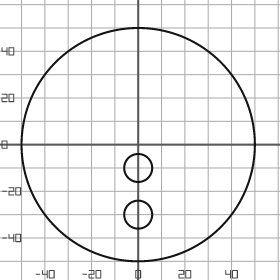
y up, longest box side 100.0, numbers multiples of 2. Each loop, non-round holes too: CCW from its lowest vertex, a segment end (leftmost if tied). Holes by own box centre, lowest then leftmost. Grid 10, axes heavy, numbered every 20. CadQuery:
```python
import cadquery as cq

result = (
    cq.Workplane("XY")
    .moveTo(0.0, 0.0)
    .circle(50.0)
    .moveTo(0.0, -30.0)
    .circle(6.0)
    .moveTo(0.0, -10.0)
    .circle(6.0)
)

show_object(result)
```